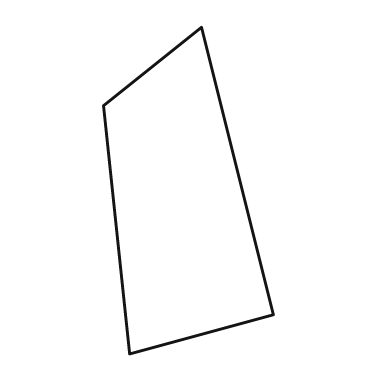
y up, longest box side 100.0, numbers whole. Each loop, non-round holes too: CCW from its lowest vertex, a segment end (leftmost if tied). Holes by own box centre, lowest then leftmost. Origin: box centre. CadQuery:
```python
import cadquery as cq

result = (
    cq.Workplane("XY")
    .moveTo(-18.0, -50.0)
    .lineTo(26.0, -38.0)
    .lineTo(4.0, 50.0)
    .lineTo(-26.0, 26.0)
    .close()
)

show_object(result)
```